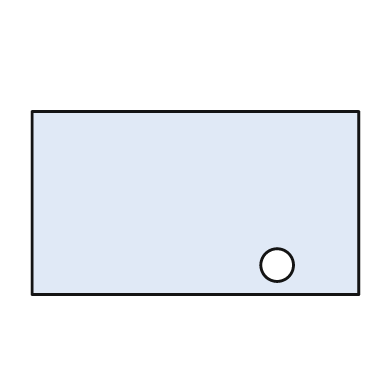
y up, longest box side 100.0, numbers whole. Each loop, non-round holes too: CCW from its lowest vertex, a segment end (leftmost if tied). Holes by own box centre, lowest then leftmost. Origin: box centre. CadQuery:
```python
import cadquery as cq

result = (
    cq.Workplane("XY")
    .moveTo(-50.0, -28.0)
    .lineTo(50.0, -28.0)
    .lineTo(50.0, 28.0)
    .lineTo(-50.0, 28.0)
    .close()
    .moveTo(25.0, -19.0)
    .circle(5.0)
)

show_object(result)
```